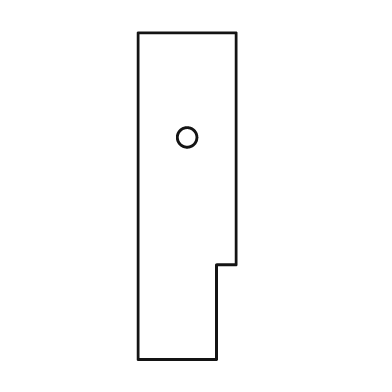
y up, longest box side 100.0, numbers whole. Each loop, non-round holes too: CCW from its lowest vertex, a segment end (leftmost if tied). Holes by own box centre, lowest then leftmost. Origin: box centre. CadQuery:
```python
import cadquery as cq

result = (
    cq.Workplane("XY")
    .moveTo(-15.0, -50.0)
    .lineTo(9.0, -50.0)
    .lineTo(9.0, -21.0)
    .lineTo(15.0, -21.0)
    .lineTo(15.0, 50.0)
    .lineTo(-15.0, 50.0)
    .close()
    .moveTo(0.0, 18.0)
    .circle(3.0)
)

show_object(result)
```